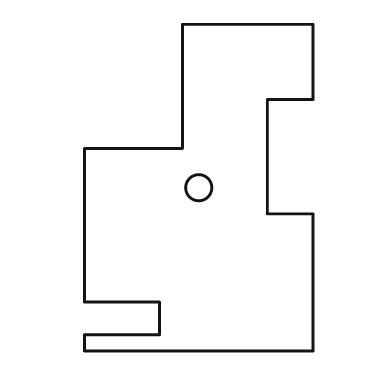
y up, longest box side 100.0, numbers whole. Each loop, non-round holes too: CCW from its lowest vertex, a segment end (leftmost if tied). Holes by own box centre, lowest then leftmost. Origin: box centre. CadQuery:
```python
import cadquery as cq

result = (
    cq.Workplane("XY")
    .moveTo(-35.0, -50.0)
    .lineTo(35.0, -50.0)
    .lineTo(35.0, -8.0)
    .lineTo(21.0, -8.0)
    .lineTo(21.0, 27.0)
    .lineTo(35.0, 27.0)
    .lineTo(35.0, 50.0)
    .lineTo(-5.0, 50.0)
    .lineTo(-5.0, 12.0)
    .lineTo(-35.0, 12.0)
    .lineTo(-35.0, -35.0)
    .lineTo(-12.0, -35.0)
    .lineTo(-12.0, -45.0)
    .lineTo(-35.0, -45.0)
    .close()
    .moveTo(0.0, 0.0)
    .circle(4.0)
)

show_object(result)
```